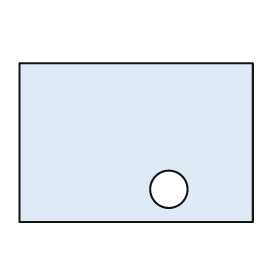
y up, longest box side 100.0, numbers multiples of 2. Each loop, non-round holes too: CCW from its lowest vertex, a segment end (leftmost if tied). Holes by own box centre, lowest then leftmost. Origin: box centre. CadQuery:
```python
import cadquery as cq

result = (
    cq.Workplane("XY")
    .moveTo(-50.0, -34.0)
    .lineTo(50.0, -34.0)
    .lineTo(50.0, 34.0)
    .lineTo(-50.0, 34.0)
    .close()
    .moveTo(14.0, -20.0)
    .circle(8.0)
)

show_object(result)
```